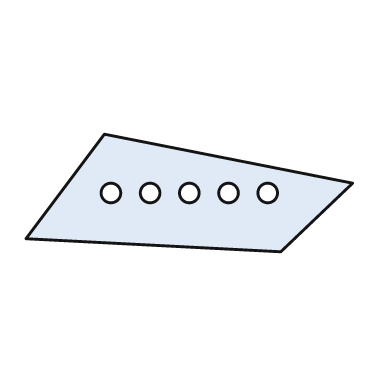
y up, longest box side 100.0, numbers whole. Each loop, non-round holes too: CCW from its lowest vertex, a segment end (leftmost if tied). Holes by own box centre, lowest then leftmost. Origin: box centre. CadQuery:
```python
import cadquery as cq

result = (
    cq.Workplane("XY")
    .moveTo(28.0, -18.0)
    .lineTo(50.0, 3.0)
    .lineTo(-26.0, 18.0)
    .lineTo(-50.0, -14.0)
    .close()
    .moveTo(-24.0, 0.0)
    .circle(3.0)
    .moveTo(-12.0, 0.0)
    .circle(3.0)
    .moveTo(0.0, 0.0)
    .circle(3.0)
    .moveTo(12.0, 0.0)
    .circle(3.0)
    .moveTo(24.0, 0.0)
    .circle(3.0)
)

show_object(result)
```